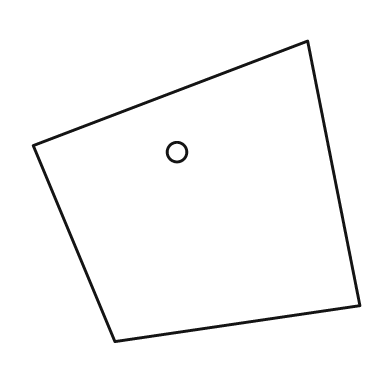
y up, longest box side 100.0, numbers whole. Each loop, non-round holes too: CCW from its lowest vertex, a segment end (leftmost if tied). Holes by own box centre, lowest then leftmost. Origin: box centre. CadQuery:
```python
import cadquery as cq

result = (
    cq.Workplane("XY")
    .moveTo(-25.0, -46.0)
    .lineTo(50.0, -35.0)
    .lineTo(34.0, 46.0)
    .lineTo(-50.0, 14.0)
    .close()
    .moveTo(-6.0, 12.0)
    .circle(3.0)
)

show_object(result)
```